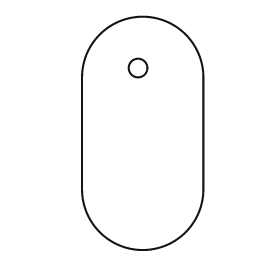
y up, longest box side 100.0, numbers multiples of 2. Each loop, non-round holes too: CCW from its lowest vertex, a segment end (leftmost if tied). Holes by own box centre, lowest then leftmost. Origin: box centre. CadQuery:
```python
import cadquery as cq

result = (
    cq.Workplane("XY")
    .moveTo(-26.0, -24.0)
    .threePointArc((0.0, -50.0), (26.0, -24.0))
    .lineTo(26.0, 24.0)
    .threePointArc((0.0, 50.0), (-26.0, 24.0))
    .close()
    .moveTo(-2.0, 28.0)
    .circle(4.0)
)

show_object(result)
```